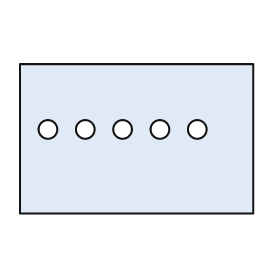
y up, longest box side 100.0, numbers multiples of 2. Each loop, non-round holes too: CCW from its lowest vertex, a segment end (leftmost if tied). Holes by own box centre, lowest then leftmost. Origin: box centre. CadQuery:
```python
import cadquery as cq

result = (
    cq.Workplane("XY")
    .moveTo(-50.0, -32.0)
    .lineTo(50.0, -32.0)
    .lineTo(50.0, 32.0)
    .lineTo(-50.0, 32.0)
    .close()
    .moveTo(-38.0, 4.0)
    .circle(4.0)
    .moveTo(-22.0, 4.0)
    .circle(4.0)
    .moveTo(-6.0, 4.0)
    .circle(4.0)
    .moveTo(10.0, 4.0)
    .circle(4.0)
    .moveTo(26.0, 4.0)
    .circle(4.0)
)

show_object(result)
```